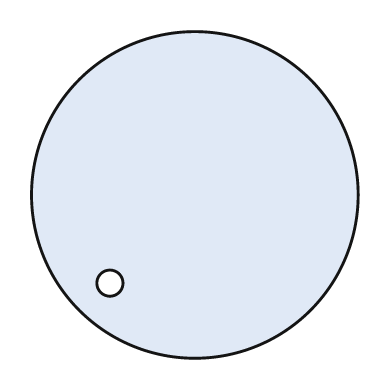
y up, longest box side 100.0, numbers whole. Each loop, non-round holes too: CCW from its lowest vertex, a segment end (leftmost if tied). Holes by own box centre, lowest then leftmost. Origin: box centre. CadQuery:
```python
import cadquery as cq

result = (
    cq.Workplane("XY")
    .moveTo(0.0, 0.0)
    .circle(50.0)
    .moveTo(-26.0, -27.0)
    .circle(4.0)
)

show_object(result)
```